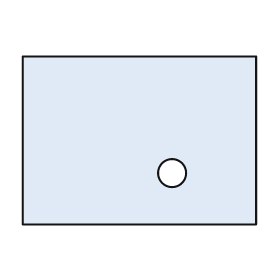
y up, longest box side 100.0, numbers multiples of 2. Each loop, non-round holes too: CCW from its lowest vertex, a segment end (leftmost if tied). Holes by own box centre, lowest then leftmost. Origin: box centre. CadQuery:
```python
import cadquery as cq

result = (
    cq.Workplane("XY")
    .moveTo(-50.0, -36.0)
    .lineTo(50.0, -36.0)
    .lineTo(50.0, 36.0)
    .lineTo(-50.0, 36.0)
    .close()
    .moveTo(14.0, -14.0)
    .circle(6.0)
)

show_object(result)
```